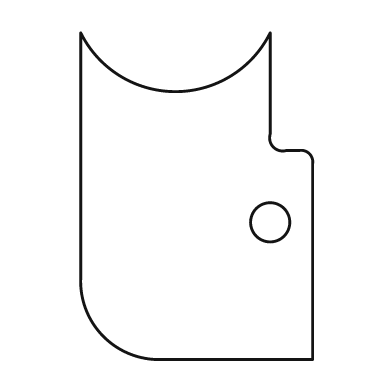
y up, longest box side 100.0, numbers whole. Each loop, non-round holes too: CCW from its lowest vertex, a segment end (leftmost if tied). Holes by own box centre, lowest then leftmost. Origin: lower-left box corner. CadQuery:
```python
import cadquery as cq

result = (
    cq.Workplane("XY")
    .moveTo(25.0, 0.0)
    .lineTo(71.0, 0.0)
    .lineTo(71.0, 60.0)
    .threePointArc((70.0, 63.0), (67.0, 64.0))
    .lineTo(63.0, 64.0)
    .threePointArc((59.0, 65.0), (58.0, 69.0))
    .lineTo(58.0, 100.0)
    .threePointArc((29.0, 82.0), (0.0, 100.0))
    .lineTo(0.0, 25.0)
    .threePointArc((7.0, 7.0), (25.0, 0.0))
    .close()
    .moveTo(58.0, 42.0)
    .circle(6.0)
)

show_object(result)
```